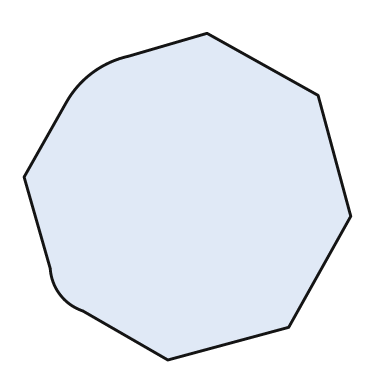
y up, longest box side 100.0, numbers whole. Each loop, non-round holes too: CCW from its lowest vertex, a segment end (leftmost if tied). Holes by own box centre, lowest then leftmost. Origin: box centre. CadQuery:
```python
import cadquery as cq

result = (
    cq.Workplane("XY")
    .moveTo(-6.0, -50.0)
    .lineTo(31.0, -40.0)
    .lineTo(50.0, -6.0)
    .lineTo(40.0, 31.0)
    .lineTo(6.0, 50.0)
    .lineTo(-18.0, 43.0)
    .threePointArc((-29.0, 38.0), (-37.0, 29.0))
    .lineTo(-50.0, 6.0)
    .lineTo(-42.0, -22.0)
    .threePointArc((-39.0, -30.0), (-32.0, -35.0))
    .close()
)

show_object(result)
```